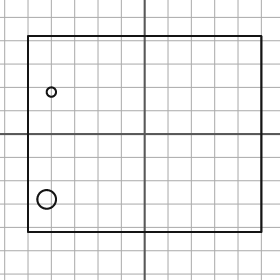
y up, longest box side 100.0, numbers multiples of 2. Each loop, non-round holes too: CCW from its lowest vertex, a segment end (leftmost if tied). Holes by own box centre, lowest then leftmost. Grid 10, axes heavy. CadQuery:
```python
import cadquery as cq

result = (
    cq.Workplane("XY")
    .moveTo(-50.0, -42.0)
    .lineTo(50.0, -42.0)
    .lineTo(50.0, 42.0)
    .lineTo(-50.0, 42.0)
    .close()
    .moveTo(-42.0, -28.0)
    .circle(4.0)
    .moveTo(-40.0, 18.0)
    .circle(2.0)
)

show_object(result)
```